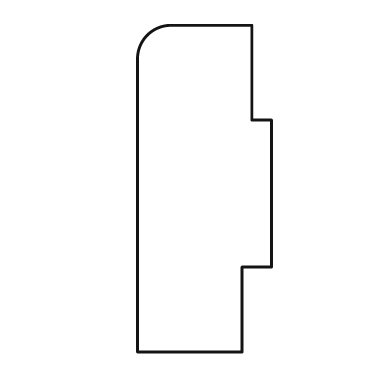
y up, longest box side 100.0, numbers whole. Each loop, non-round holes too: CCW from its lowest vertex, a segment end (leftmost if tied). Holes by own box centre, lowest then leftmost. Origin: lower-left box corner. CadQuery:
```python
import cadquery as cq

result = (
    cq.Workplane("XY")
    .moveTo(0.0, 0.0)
    .lineTo(32.0, 0.0)
    .lineTo(32.0, 26.0)
    .lineTo(41.0, 26.0)
    .lineTo(41.0, 71.0)
    .lineTo(35.0, 71.0)
    .lineTo(35.0, 100.0)
    .lineTo(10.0, 100.0)
    .threePointArc((3.0, 97.0), (0.0, 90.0))
    .close()
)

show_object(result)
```